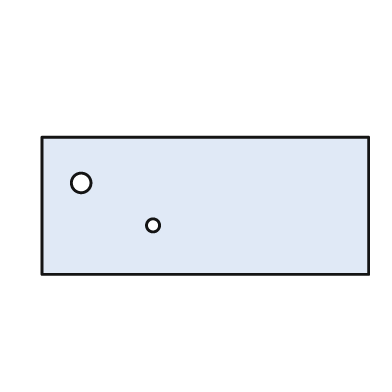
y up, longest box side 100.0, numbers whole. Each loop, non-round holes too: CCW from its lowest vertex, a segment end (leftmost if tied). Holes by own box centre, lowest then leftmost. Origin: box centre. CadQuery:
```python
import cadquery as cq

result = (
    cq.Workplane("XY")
    .moveTo(-50.0, -21.0)
    .lineTo(50.0, -21.0)
    .lineTo(50.0, 21.0)
    .lineTo(-50.0, 21.0)
    .close()
    .moveTo(-16.0, -6.0)
    .circle(2.0)
    .moveTo(-38.0, 7.0)
    .circle(3.0)
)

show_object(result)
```